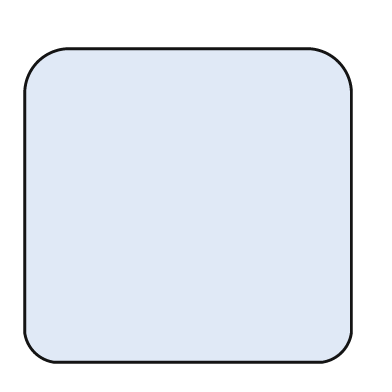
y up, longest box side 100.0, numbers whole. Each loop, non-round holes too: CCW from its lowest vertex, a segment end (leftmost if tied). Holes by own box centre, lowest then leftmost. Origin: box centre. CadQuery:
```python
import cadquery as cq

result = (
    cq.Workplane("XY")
    .moveTo(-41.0, -48.0)
    .lineTo(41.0, -48.0)
    .threePointArc((47.0, -45.0), (50.0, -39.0))
    .lineTo(50.0, 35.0)
    .threePointArc((46.0, 44.0), (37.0, 48.0))
    .lineTo(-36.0, 48.0)
    .threePointArc((-46.0, 44.0), (-50.0, 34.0))
    .lineTo(-50.0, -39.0)
    .threePointArc((-47.0, -45.0), (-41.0, -48.0))
    .close()
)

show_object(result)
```